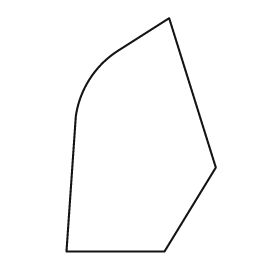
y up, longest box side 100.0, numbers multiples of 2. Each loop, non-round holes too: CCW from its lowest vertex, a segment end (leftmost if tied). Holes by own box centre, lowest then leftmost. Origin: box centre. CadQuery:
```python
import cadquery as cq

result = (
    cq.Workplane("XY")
    .moveTo(-32.0, -50.0)
    .lineTo(10.0, -50.0)
    .lineTo(32.0, -14.0)
    .lineTo(12.0, 50.0)
    .lineTo(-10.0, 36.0)
    .threePointArc((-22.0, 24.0), (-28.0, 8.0))
    .close()
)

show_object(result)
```